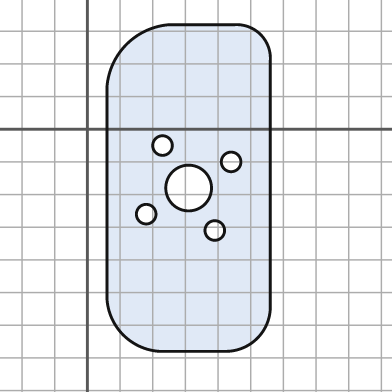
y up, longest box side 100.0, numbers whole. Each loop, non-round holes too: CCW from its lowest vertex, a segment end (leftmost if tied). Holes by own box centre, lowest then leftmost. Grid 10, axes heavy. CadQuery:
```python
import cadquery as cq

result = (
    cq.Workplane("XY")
    .moveTo(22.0, -68.0)
    .lineTo(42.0, -68.0)
    .threePointArc((52.0, -64.0), (56.0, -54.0))
    .lineTo(56.0, 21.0)
    .threePointArc((53.0, 29.0), (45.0, 32.0))
    .lineTo(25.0, 32.0)
    .threePointArc((12.0, 26.0), (6.0, 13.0))
    .lineTo(6.0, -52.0)
    .threePointArc((11.0, -63.0), (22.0, -68.0))
    .close()
    .moveTo(39.0, -31.0)
    .circle(3.0)
    .moveTo(18.0, -26.0)
    .circle(3.0)
    .moveTo(31.0, -18.0)
    .circle(7.0)
    .moveTo(44.0, -10.0)
    .circle(3.0)
    .moveTo(23.0, -5.0)
    .circle(3.0)
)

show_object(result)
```